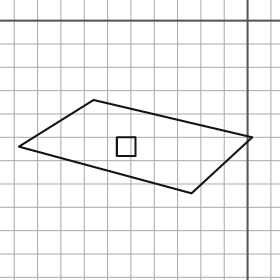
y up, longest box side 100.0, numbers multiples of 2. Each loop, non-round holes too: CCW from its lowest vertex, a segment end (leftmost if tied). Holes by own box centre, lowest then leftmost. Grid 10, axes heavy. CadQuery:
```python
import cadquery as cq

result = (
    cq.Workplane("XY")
    .moveTo(-24.0, -74.0)
    .lineTo(2.0, -50.0)
    .lineTo(-66.0, -34.0)
    .lineTo(-98.0, -54.0)
    .close()
    .moveTo(-56.0, -58.0)
    .lineTo(-48.0, -58.0)
    .lineTo(-48.0, -50.0)
    .lineTo(-56.0, -50.0)
    .close()
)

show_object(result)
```